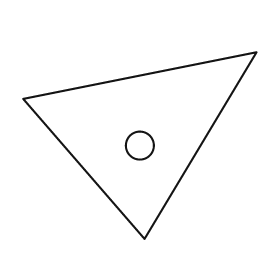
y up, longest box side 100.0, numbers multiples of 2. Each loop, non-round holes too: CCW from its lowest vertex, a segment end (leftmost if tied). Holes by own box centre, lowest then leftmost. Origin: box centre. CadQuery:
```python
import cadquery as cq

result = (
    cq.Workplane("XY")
    .moveTo(2.0, -40.0)
    .lineTo(50.0, 40.0)
    .lineTo(-50.0, 20.0)
    .close()
    .moveTo(0.0, 0.0)
    .circle(6.0)
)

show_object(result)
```